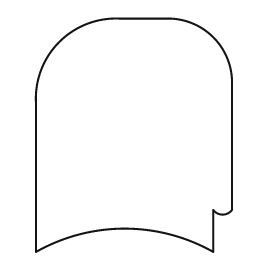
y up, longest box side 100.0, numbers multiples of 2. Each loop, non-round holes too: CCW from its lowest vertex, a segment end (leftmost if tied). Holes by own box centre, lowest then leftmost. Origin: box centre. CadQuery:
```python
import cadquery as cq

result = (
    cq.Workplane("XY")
    .moveTo(-42.0, -50.0)
    .threePointArc((-4.0, -40.0), (34.0, -50.0))
    .lineTo(34.0, -32.0)
    .threePointArc((38.0, -34.0), (42.0, -32.0))
    .lineTo(42.0, 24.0)
    .threePointArc((34.0, 42.0), (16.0, 50.0))
    .lineTo(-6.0, 50.0)
    .threePointArc((-32.0, 40.0), (-42.0, 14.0))
    .close()
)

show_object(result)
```